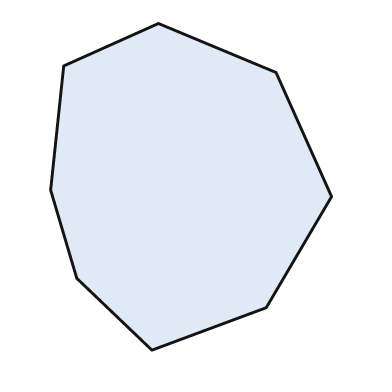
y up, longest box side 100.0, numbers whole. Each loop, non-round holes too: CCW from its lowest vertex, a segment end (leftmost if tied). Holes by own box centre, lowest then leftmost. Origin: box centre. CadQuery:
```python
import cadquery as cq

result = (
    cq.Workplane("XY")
    .moveTo(-12.0, -50.0)
    .lineTo(23.0, -37.0)
    .lineTo(43.0, -3.0)
    .lineTo(26.0, 35.0)
    .lineTo(-10.0, 50.0)
    .lineTo(-39.0, 37.0)
    .lineTo(-43.0, -1.0)
    .lineTo(-35.0, -28.0)
    .close()
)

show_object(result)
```